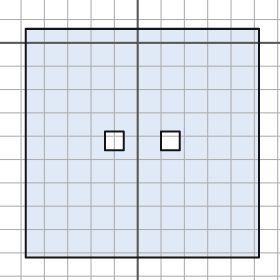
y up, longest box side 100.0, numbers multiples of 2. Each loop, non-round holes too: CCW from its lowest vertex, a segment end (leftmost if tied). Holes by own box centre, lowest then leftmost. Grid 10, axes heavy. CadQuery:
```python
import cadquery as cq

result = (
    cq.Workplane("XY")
    .moveTo(-48.0, -92.0)
    .lineTo(52.0, -92.0)
    .lineTo(52.0, 6.0)
    .lineTo(-48.0, 6.0)
    .close()
    .moveTo(-14.0, -46.0)
    .lineTo(-6.0, -46.0)
    .lineTo(-6.0, -38.0)
    .lineTo(-14.0, -38.0)
    .close()
    .moveTo(10.0, -46.0)
    .lineTo(18.0, -46.0)
    .lineTo(18.0, -38.0)
    .lineTo(10.0, -38.0)
    .close()
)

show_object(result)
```